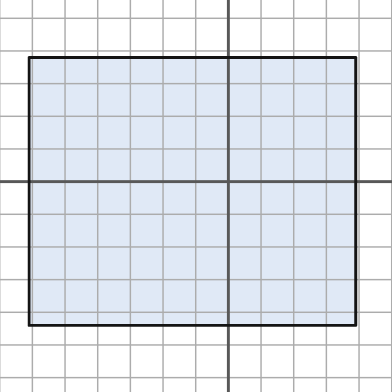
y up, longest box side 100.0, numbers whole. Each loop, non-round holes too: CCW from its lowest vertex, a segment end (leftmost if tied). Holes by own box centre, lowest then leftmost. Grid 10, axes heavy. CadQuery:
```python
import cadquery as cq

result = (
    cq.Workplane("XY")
    .moveTo(-61.0, -44.0)
    .lineTo(39.0, -44.0)
    .lineTo(39.0, 38.0)
    .lineTo(-61.0, 38.0)
    .close()
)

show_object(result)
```